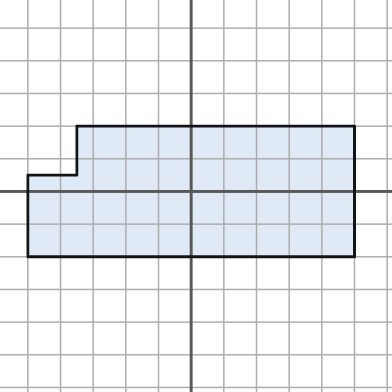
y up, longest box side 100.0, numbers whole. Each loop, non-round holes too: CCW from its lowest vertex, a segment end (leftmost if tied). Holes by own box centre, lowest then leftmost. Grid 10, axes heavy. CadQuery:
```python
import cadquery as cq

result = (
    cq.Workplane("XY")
    .moveTo(-50.0, -20.0)
    .lineTo(50.0, -20.0)
    .lineTo(50.0, 20.0)
    .lineTo(-35.0, 20.0)
    .lineTo(-35.0, 5.0)
    .lineTo(-50.0, 5.0)
    .close()
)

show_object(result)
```